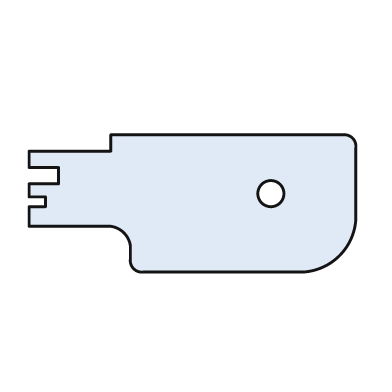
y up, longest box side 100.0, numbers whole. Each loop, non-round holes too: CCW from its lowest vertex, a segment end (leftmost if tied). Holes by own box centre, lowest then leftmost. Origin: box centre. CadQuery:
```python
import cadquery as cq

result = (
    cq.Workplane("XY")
    .moveTo(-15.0, -21.0)
    .lineTo(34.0, -21.0)
    .threePointArc((45.0, -16.0), (50.0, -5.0))
    .lineTo(50.0, 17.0)
    .threePointArc((49.0, 20.0), (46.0, 21.0))
    .lineTo(-25.0, 21.0)
    .lineTo(-25.0, 16.0)
    .lineTo(-50.0, 16.0)
    .lineTo(-50.0, 11.0)
    .lineTo(-41.0, 11.0)
    .lineTo(-41.0, 6.0)
    .lineTo(-50.0, 6.0)
    .lineTo(-50.0, 2.0)
    .lineTo(-45.0, 2.0)
    .lineTo(-45.0, -1.0)
    .lineTo(-50.0, -1.0)
    .lineTo(-50.0, -7.0)
    .lineTo(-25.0, -7.0)
    .threePointArc((-21.0, -9.0), (-19.0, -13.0))
    .lineTo(-19.0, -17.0)
    .threePointArc((-18.0, -20.0), (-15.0, -21.0))
    .close()
    .moveTo(24.0, 3.0)
    .circle(4.0)
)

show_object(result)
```